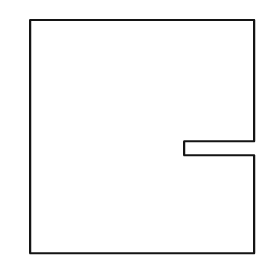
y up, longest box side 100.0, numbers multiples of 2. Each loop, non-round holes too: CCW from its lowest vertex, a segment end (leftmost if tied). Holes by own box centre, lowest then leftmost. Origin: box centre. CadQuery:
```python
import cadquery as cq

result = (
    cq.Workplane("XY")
    .moveTo(-48.0, -50.0)
    .lineTo(48.0, -50.0)
    .lineTo(48.0, -8.0)
    .lineTo(18.0, -8.0)
    .lineTo(18.0, -2.0)
    .lineTo(48.0, -2.0)
    .lineTo(48.0, 50.0)
    .lineTo(-48.0, 50.0)
    .close()
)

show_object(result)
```